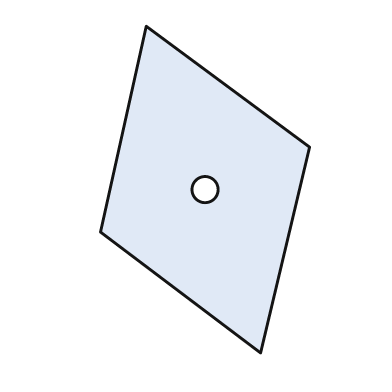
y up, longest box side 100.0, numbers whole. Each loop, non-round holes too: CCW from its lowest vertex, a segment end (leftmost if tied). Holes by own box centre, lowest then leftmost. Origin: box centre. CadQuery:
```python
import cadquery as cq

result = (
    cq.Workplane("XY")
    .moveTo(17.0, -50.0)
    .lineTo(32.0, 13.0)
    .lineTo(-18.0, 50.0)
    .lineTo(-32.0, -13.0)
    .close()
    .moveTo(0.0, 0.0)
    .circle(4.0)
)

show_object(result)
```